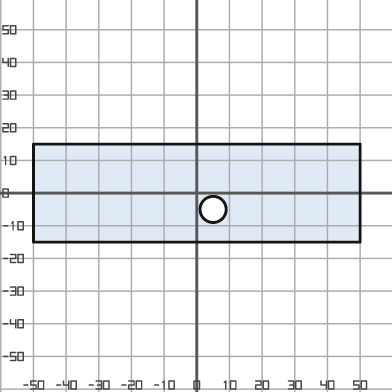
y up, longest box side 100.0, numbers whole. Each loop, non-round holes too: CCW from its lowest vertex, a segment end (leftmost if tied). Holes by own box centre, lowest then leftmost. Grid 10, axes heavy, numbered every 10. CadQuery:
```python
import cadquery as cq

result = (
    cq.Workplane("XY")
    .moveTo(-50.0, -15.0)
    .lineTo(50.0, -15.0)
    .lineTo(50.0, 15.0)
    .lineTo(-50.0, 15.0)
    .close()
    .moveTo(5.0, -5.0)
    .circle(4.0)
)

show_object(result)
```